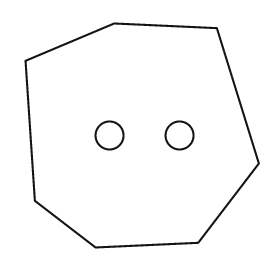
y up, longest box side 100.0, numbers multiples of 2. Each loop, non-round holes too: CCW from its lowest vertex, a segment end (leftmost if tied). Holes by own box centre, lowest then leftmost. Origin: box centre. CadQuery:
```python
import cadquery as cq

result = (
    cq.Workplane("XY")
    .moveTo(-20.0, -48.0)
    .lineTo(24.0, -46.0)
    .lineTo(50.0, -12.0)
    .lineTo(32.0, 46.0)
    .lineTo(-12.0, 48.0)
    .lineTo(-50.0, 32.0)
    .lineTo(-46.0, -28.0)
    .close()
    .moveTo(-14.0, 0.0)
    .circle(6.0)
    .moveTo(16.0, 0.0)
    .circle(6.0)
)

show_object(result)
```